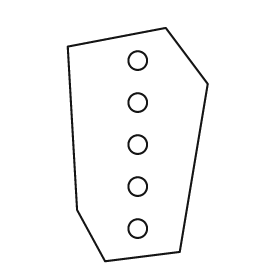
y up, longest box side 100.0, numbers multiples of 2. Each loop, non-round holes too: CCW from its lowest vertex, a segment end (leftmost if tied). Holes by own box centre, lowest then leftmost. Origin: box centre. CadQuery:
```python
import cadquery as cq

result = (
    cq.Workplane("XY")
    .moveTo(-14.0, -50.0)
    .lineTo(18.0, -46.0)
    .lineTo(30.0, 26.0)
    .lineTo(12.0, 50.0)
    .lineTo(-30.0, 42.0)
    .lineTo(-26.0, -28.0)
    .close()
    .moveTo(0.0, -36.0)
    .circle(4.0)
    .moveTo(0.0, -18.0)
    .circle(4.0)
    .moveTo(0.0, 0.0)
    .circle(4.0)
    .moveTo(0.0, 18.0)
    .circle(4.0)
    .moveTo(0.0, 36.0)
    .circle(4.0)
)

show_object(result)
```